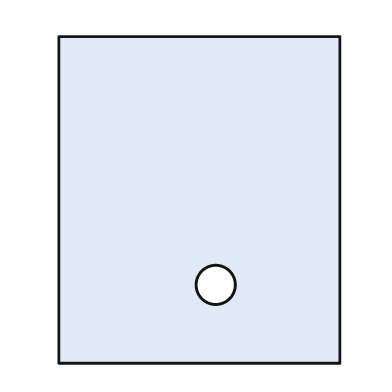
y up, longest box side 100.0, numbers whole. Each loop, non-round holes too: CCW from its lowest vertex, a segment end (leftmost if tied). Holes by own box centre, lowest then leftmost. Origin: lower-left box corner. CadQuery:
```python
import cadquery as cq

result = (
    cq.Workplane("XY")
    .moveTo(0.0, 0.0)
    .lineTo(86.0, 0.0)
    .lineTo(86.0, 100.0)
    .lineTo(0.0, 100.0)
    .close()
    .moveTo(48.0, 24.0)
    .circle(6.0)
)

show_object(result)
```